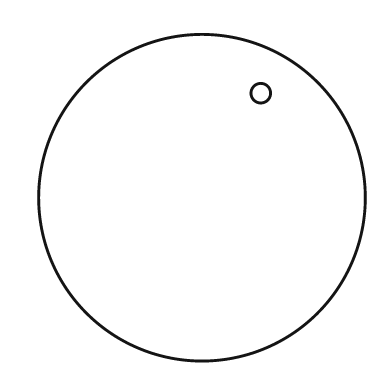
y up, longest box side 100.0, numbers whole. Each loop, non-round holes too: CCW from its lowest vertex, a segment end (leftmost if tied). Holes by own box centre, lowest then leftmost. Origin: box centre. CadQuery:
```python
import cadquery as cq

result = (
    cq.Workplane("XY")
    .moveTo(0.0, 0.0)
    .circle(50.0)
    .moveTo(18.0, 32.0)
    .circle(3.0)
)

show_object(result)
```